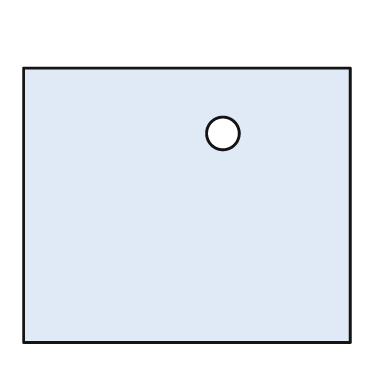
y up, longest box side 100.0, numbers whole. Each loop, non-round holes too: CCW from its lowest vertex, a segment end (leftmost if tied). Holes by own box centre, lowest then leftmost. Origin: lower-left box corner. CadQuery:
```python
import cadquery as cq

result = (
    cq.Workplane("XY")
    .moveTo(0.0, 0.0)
    .lineTo(100.0, 0.0)
    .lineTo(100.0, 84.0)
    .lineTo(0.0, 84.0)
    .close()
    .moveTo(61.0, 64.0)
    .circle(5.0)
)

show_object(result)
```